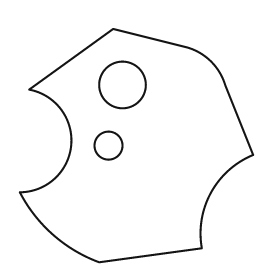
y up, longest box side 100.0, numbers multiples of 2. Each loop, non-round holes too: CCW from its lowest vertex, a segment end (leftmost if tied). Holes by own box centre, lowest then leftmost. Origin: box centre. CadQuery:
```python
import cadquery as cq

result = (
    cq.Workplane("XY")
    .moveTo(-16.0, -50.0)
    .lineTo(28.0, -44.0)
    .threePointArc((32.0, -20.0), (50.0, -4.0))
    .lineTo(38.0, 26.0)
    .threePointArc((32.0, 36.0), (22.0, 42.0))
    .lineTo(-10.0, 50.0)
    .lineTo(-46.0, 24.0)
    .threePointArc((-28.0, 0.0), (-50.0, -20.0))
    .threePointArc((-36.0, -38.0), (-16.0, -50.0))
    .close()
    .moveTo(-12.0, 0.0)
    .circle(6.0)
    .moveTo(-6.0, 26.0)
    .circle(10.0)
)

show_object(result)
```